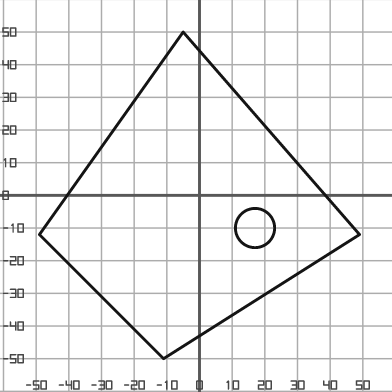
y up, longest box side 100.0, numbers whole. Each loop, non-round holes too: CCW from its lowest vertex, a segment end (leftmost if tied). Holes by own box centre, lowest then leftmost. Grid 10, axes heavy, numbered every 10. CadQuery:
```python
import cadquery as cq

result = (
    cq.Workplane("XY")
    .moveTo(-11.0, -50.0)
    .lineTo(49.0, -12.0)
    .lineTo(-5.0, 50.0)
    .lineTo(-49.0, -12.0)
    .close()
    .moveTo(17.0, -10.0)
    .circle(6.0)
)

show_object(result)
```